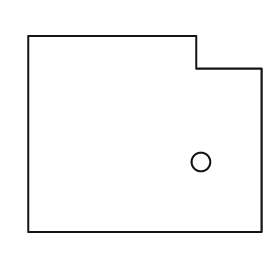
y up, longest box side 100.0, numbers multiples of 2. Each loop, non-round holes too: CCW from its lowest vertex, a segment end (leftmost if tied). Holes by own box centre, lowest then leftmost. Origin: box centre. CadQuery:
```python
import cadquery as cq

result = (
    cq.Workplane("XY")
    .moveTo(-50.0, -42.0)
    .lineTo(50.0, -42.0)
    .lineTo(50.0, 28.0)
    .lineTo(22.0, 28.0)
    .lineTo(22.0, 42.0)
    .lineTo(-50.0, 42.0)
    .close()
    .moveTo(24.0, -12.0)
    .circle(4.0)
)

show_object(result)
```